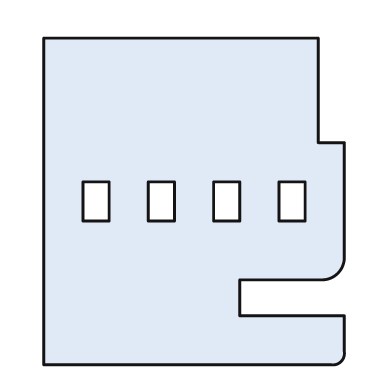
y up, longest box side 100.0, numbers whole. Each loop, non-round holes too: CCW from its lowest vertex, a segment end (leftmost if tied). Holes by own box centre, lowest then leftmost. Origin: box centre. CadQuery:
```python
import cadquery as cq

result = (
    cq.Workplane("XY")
    .moveTo(-46.0, -50.0)
    .lineTo(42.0, -50.0)
    .threePointArc((45.0, -49.0), (46.0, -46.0))
    .lineTo(46.0, -35.0)
    .lineTo(14.0, -35.0)
    .lineTo(14.0, -24.0)
    .lineTo(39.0, -24.0)
    .threePointArc((44.0, -22.0), (46.0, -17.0))
    .lineTo(46.0, 18.0)
    .lineTo(38.0, 18.0)
    .lineTo(38.0, 50.0)
    .lineTo(-46.0, 50.0)
    .close()
    .moveTo(-34.0, -6.0)
    .lineTo(-26.0, -6.0)
    .lineTo(-26.0, 6.0)
    .lineTo(-34.0, 6.0)
    .close()
    .moveTo(-14.0, -6.0)
    .lineTo(-6.0, -6.0)
    .lineTo(-6.0, 6.0)
    .lineTo(-14.0, 6.0)
    .close()
    .moveTo(6.0, -6.0)
    .lineTo(14.0, -6.0)
    .lineTo(14.0, 6.0)
    .lineTo(6.0, 6.0)
    .close()
    .moveTo(26.0, -6.0)
    .lineTo(34.0, -6.0)
    .lineTo(34.0, 6.0)
    .lineTo(26.0, 6.0)
    .close()
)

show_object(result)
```